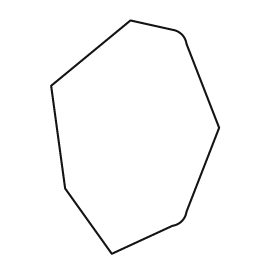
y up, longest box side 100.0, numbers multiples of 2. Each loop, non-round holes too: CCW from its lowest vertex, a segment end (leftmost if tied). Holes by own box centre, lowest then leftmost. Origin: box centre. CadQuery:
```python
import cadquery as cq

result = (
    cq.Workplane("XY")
    .moveTo(-10.0, -50.0)
    .lineTo(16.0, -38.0)
    .threePointArc((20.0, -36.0), (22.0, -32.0))
    .lineTo(36.0, 4.0)
    .lineTo(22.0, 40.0)
    .threePointArc((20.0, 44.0), (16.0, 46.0))
    .lineTo(-2.0, 50.0)
    .lineTo(-36.0, 22.0)
    .lineTo(-30.0, -22.0)
    .close()
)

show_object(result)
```